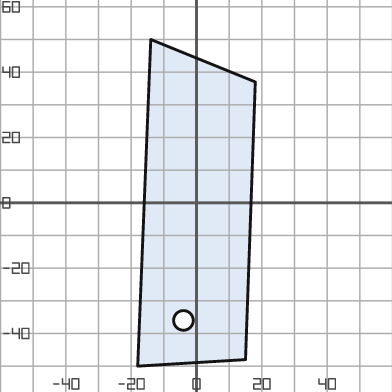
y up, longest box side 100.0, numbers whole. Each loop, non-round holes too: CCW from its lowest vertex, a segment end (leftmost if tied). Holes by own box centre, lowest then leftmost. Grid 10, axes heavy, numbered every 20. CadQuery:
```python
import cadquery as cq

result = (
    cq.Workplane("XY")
    .moveTo(-18.0, -50.0)
    .lineTo(15.0, -48.0)
    .lineTo(18.0, 37.0)
    .lineTo(-14.0, 50.0)
    .close()
    .moveTo(-4.0, -36.0)
    .circle(3.0)
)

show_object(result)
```